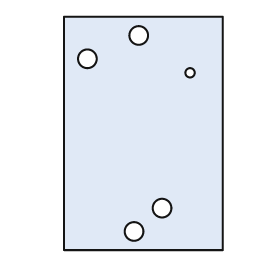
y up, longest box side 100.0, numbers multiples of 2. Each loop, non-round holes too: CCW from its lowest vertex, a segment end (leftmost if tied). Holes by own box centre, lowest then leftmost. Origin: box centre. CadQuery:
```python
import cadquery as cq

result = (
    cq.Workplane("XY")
    .moveTo(-34.0, -50.0)
    .lineTo(34.0, -50.0)
    .lineTo(34.0, 50.0)
    .lineTo(-34.0, 50.0)
    .close()
    .moveTo(-4.0, -42.0)
    .circle(4.0)
    .moveTo(8.0, -32.0)
    .circle(4.0)
    .moveTo(20.0, 26.0)
    .circle(2.0)
    .moveTo(-24.0, 32.0)
    .circle(4.0)
    .moveTo(-2.0, 42.0)
    .circle(4.0)
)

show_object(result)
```